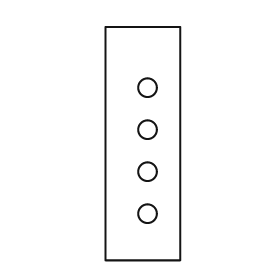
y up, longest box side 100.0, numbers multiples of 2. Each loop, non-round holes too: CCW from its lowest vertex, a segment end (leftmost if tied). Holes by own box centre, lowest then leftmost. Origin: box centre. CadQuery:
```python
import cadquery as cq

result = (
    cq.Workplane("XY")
    .moveTo(-16.0, -50.0)
    .lineTo(16.0, -50.0)
    .lineTo(16.0, 50.0)
    .lineTo(-16.0, 50.0)
    .close()
    .moveTo(2.0, -30.0)
    .circle(4.0)
    .moveTo(2.0, -12.0)
    .circle(4.0)
    .moveTo(2.0, 6.0)
    .circle(4.0)
    .moveTo(2.0, 24.0)
    .circle(4.0)
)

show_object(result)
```